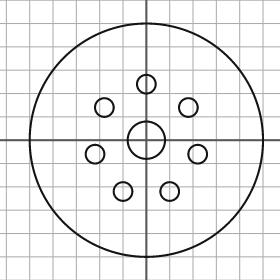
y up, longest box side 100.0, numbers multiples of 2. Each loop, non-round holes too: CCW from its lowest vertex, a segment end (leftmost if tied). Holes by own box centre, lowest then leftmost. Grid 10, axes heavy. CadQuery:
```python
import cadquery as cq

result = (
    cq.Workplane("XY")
    .moveTo(0.0, 0.0)
    .circle(50.0)
    .moveTo(-10.0, -22.0)
    .circle(4.0)
    .moveTo(10.0, -22.0)
    .circle(4.0)
    .moveTo(-22.0, -6.0)
    .circle(4.0)
    .moveTo(22.0, -6.0)
    .circle(4.0)
    .moveTo(0.0, 0.0)
    .circle(8.0)
    .moveTo(-18.0, 14.0)
    .circle(4.0)
    .moveTo(18.0, 14.0)
    .circle(4.0)
    .moveTo(0.0, 24.0)
    .circle(4.0)
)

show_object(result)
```